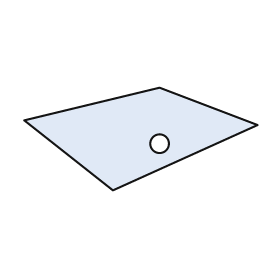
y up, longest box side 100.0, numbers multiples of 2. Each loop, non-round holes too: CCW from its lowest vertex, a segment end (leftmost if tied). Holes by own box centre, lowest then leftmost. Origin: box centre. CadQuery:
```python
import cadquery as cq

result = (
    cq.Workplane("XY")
    .moveTo(-12.0, -22.0)
    .lineTo(50.0, 6.0)
    .lineTo(8.0, 22.0)
    .lineTo(-50.0, 8.0)
    .close()
    .moveTo(8.0, -2.0)
    .circle(4.0)
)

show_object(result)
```